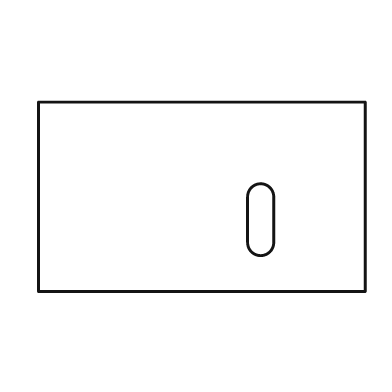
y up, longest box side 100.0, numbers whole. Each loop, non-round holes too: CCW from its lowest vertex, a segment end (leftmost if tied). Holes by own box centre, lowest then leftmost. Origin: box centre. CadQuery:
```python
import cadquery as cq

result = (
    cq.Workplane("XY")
    .moveTo(-50.0, -29.0)
    .lineTo(50.0, -29.0)
    .lineTo(50.0, 29.0)
    .lineTo(-50.0, 29.0)
    .close()
    .moveTo(14.0, -14.0)
    .threePointArc((18.0, -18.0), (22.0, -14.0))
    .lineTo(22.0, 0.0)
    .threePointArc((18.0, 4.0), (14.0, 0.0))
    .close()
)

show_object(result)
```